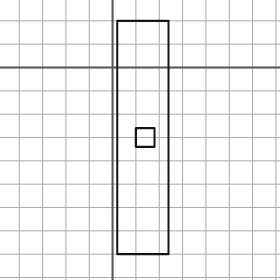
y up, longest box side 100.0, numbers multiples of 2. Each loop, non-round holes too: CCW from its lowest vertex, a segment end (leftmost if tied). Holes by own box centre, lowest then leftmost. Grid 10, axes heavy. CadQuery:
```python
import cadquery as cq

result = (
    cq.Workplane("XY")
    .moveTo(2.0, -80.0)
    .lineTo(24.0, -80.0)
    .lineTo(24.0, 20.0)
    .lineTo(2.0, 20.0)
    .close()
    .moveTo(10.0, -34.0)
    .lineTo(18.0, -34.0)
    .lineTo(18.0, -26.0)
    .lineTo(10.0, -26.0)
    .close()
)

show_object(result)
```